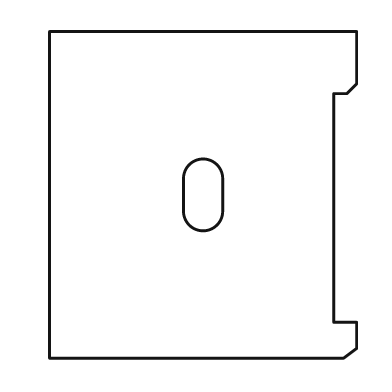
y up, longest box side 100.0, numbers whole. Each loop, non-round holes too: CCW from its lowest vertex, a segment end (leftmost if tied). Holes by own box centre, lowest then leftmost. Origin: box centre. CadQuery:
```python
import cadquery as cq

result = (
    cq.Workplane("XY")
    .moveTo(-47.0, -50.0)
    .lineTo(43.0, -50.0)
    .lineTo(47.0, -47.0)
    .lineTo(47.0, -39.0)
    .lineTo(40.0, -39.0)
    .lineTo(40.0, 31.0)
    .lineTo(44.0, 31.0)
    .lineTo(47.0, 34.0)
    .lineTo(47.0, 50.0)
    .lineTo(-47.0, 50.0)
    .close()
    .moveTo(-6.0, -5.0)
    .threePointArc((0.0, -11.0), (6.0, -5.0))
    .lineTo(6.0, 5.0)
    .threePointArc((0.0, 11.0), (-6.0, 5.0))
    .close()
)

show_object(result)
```